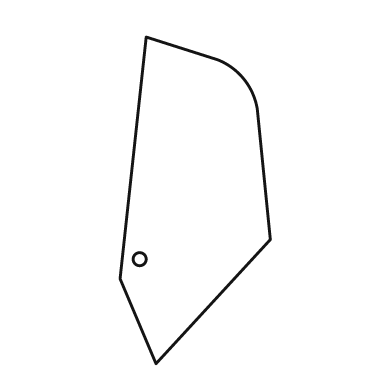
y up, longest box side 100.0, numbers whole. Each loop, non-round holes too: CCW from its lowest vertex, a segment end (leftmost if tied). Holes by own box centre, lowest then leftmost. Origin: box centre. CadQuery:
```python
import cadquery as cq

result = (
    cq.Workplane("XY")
    .moveTo(-12.0, -50.0)
    .lineTo(23.0, -12.0)
    .lineTo(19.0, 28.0)
    .threePointArc((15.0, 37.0), (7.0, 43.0))
    .lineTo(-15.0, 50.0)
    .lineTo(-23.0, -24.0)
    .close()
    .moveTo(-17.0, -18.0)
    .circle(2.0)
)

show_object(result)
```